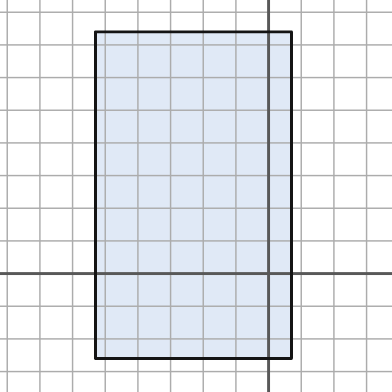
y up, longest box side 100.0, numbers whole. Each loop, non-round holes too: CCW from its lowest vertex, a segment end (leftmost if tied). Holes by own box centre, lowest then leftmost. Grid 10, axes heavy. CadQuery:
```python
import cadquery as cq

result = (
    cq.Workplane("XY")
    .moveTo(-53.0, -26.0)
    .lineTo(7.0, -26.0)
    .lineTo(7.0, 74.0)
    .lineTo(-53.0, 74.0)
    .close()
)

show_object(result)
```